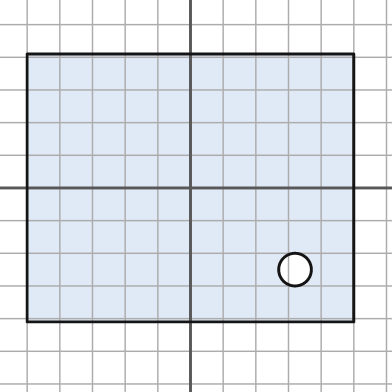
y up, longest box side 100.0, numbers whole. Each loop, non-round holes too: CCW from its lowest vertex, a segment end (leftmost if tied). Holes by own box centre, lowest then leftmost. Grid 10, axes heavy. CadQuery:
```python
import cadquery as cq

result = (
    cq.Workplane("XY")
    .moveTo(-50.0, -41.0)
    .lineTo(50.0, -41.0)
    .lineTo(50.0, 41.0)
    .lineTo(-50.0, 41.0)
    .close()
    .moveTo(32.0, -25.0)
    .circle(5.0)
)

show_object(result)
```